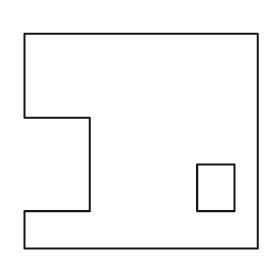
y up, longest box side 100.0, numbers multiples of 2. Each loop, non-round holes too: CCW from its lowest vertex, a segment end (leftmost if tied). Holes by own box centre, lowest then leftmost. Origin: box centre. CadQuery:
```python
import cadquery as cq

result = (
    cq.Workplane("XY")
    .moveTo(-50.0, -46.0)
    .lineTo(50.0, -46.0)
    .lineTo(50.0, 46.0)
    .lineTo(-50.0, 46.0)
    .lineTo(-50.0, 10.0)
    .lineTo(-22.0, 10.0)
    .lineTo(-22.0, -30.0)
    .lineTo(-50.0, -30.0)
    .close()
    .moveTo(24.0, -30.0)
    .lineTo(40.0, -30.0)
    .lineTo(40.0, -10.0)
    .lineTo(24.0, -10.0)
    .close()
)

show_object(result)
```